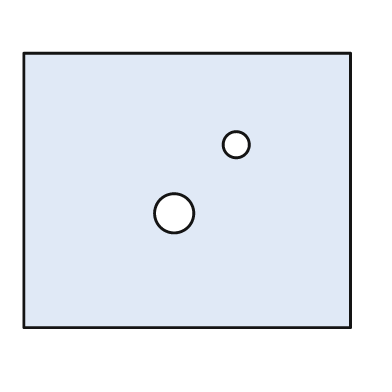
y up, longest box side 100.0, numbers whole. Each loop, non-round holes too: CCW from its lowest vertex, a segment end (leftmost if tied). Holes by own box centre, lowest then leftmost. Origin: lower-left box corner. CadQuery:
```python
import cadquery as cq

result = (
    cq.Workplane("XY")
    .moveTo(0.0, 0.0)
    .lineTo(100.0, 0.0)
    .lineTo(100.0, 84.0)
    .lineTo(0.0, 84.0)
    .close()
    .moveTo(46.0, 35.0)
    .circle(6.0)
    .moveTo(65.0, 56.0)
    .circle(4.0)
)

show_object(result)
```